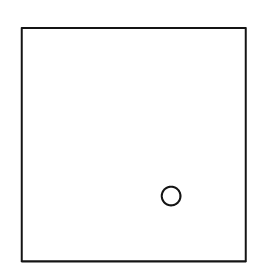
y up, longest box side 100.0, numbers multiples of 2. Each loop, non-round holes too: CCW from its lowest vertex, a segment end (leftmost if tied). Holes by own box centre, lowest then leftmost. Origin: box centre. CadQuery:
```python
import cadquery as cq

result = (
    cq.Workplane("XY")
    .moveTo(-48.0, -50.0)
    .lineTo(48.0, -50.0)
    .lineTo(48.0, 50.0)
    .lineTo(-48.0, 50.0)
    .close()
    .moveTo(16.0, -22.0)
    .circle(4.0)
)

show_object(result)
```